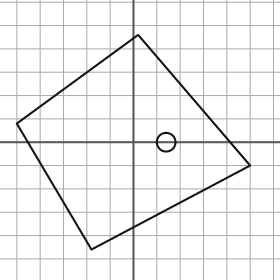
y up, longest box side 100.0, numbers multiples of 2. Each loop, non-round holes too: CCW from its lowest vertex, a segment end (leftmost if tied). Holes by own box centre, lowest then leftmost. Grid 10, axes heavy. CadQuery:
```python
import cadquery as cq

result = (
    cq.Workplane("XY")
    .moveTo(-18.0, -46.0)
    .lineTo(50.0, -10.0)
    .lineTo(2.0, 46.0)
    .lineTo(-50.0, 8.0)
    .close()
    .moveTo(14.0, 0.0)
    .circle(4.0)
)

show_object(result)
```